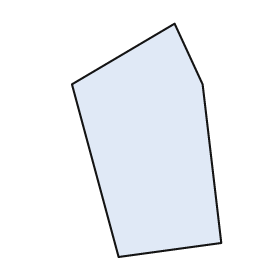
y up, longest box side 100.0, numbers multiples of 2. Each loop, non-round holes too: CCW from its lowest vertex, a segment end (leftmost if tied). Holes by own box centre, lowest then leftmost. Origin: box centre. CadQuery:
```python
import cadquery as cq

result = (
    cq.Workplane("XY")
    .moveTo(-12.0, -50.0)
    .lineTo(32.0, -44.0)
    .lineTo(24.0, 24.0)
    .lineTo(12.0, 50.0)
    .lineTo(-32.0, 24.0)
    .close()
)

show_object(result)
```